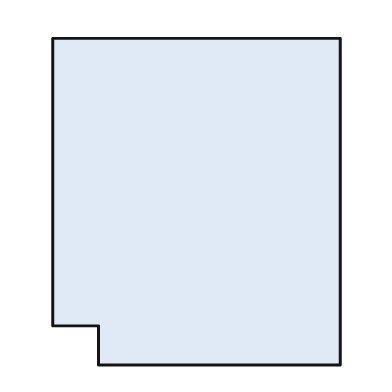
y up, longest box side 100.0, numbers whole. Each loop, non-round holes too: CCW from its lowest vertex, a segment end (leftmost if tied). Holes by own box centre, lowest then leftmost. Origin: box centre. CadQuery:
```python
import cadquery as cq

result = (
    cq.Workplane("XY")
    .moveTo(-30.0, -50.0)
    .lineTo(44.0, -50.0)
    .lineTo(44.0, 50.0)
    .lineTo(-44.0, 50.0)
    .lineTo(-44.0, -38.0)
    .lineTo(-30.0, -38.0)
    .close()
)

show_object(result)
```